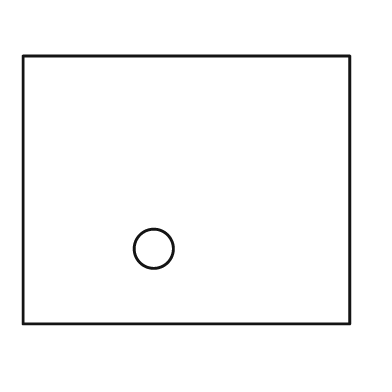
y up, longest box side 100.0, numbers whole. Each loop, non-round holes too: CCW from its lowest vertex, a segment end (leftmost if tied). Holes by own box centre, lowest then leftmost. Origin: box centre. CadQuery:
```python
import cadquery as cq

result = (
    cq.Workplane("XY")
    .moveTo(-50.0, -41.0)
    .lineTo(50.0, -41.0)
    .lineTo(50.0, 41.0)
    .lineTo(-50.0, 41.0)
    .close()
    .moveTo(-10.0, -18.0)
    .circle(6.0)
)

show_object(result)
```